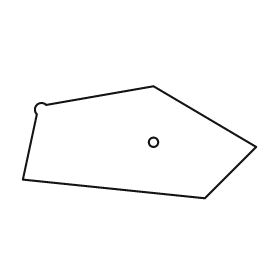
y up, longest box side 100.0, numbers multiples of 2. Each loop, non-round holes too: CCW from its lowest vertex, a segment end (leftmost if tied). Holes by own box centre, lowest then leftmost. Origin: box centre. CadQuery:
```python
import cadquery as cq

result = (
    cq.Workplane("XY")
    .moveTo(28.0, -24.0)
    .lineTo(50.0, -2.0)
    .lineTo(6.0, 24.0)
    .lineTo(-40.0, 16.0)
    .threePointArc((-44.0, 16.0), (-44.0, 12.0))
    .lineTo(-50.0, -16.0)
    .close()
    .moveTo(6.0, 0.0)
    .circle(2.0)
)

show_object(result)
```